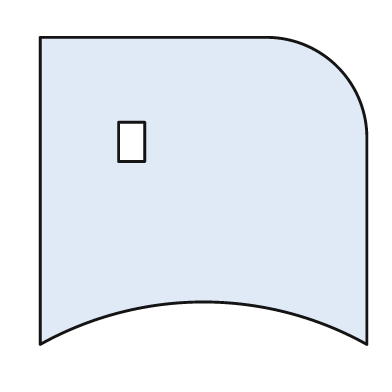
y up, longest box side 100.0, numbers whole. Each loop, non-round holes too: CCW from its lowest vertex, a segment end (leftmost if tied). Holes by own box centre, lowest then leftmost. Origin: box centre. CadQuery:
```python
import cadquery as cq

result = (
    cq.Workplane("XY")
    .moveTo(-50.0, -47.0)
    .threePointArc((0.0, -34.0), (50.0, -47.0))
    .lineTo(50.0, 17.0)
    .threePointArc((41.0, 38.0), (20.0, 47.0))
    .lineTo(-50.0, 47.0)
    .close()
    .moveTo(-26.0, 9.0)
    .lineTo(-18.0, 9.0)
    .lineTo(-18.0, 21.0)
    .lineTo(-26.0, 21.0)
    .close()
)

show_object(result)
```